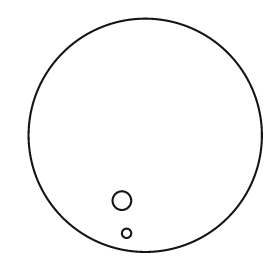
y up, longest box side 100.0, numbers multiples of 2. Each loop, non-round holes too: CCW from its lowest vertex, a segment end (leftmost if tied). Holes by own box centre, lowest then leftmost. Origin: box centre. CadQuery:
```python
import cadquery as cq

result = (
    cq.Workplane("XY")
    .moveTo(0.0, 0.0)
    .circle(50.0)
    .moveTo(-8.0, -42.0)
    .circle(2.0)
    .moveTo(-10.0, -28.0)
    .circle(4.0)
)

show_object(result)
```